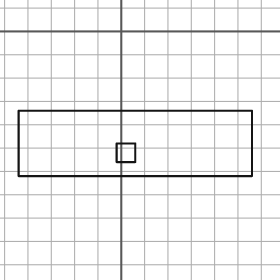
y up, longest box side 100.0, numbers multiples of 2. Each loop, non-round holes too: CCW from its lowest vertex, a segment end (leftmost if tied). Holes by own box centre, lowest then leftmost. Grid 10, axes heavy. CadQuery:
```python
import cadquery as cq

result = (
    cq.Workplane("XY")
    .moveTo(-44.0, -62.0)
    .lineTo(56.0, -62.0)
    .lineTo(56.0, -34.0)
    .lineTo(-44.0, -34.0)
    .close()
    .moveTo(-2.0, -56.0)
    .lineTo(6.0, -56.0)
    .lineTo(6.0, -48.0)
    .lineTo(-2.0, -48.0)
    .close()
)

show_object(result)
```